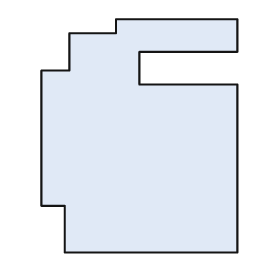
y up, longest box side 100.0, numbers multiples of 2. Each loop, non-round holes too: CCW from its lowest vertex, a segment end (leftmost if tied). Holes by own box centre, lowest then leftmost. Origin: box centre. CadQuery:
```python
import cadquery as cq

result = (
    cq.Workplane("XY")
    .moveTo(-32.0, -50.0)
    .lineTo(42.0, -50.0)
    .lineTo(42.0, 22.0)
    .lineTo(0.0, 22.0)
    .lineTo(0.0, 36.0)
    .lineTo(42.0, 36.0)
    .lineTo(42.0, 50.0)
    .lineTo(-10.0, 50.0)
    .lineTo(-10.0, 44.0)
    .lineTo(-30.0, 44.0)
    .lineTo(-30.0, 28.0)
    .lineTo(-42.0, 28.0)
    .lineTo(-42.0, -30.0)
    .lineTo(-32.0, -30.0)
    .close()
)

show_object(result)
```